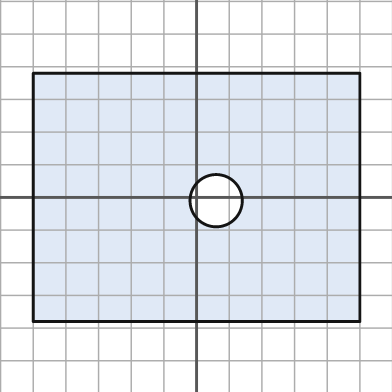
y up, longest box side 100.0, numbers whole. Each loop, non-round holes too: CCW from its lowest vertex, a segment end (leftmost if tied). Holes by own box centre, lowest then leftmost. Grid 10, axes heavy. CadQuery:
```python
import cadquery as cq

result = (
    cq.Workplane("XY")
    .moveTo(-50.0, -38.0)
    .lineTo(50.0, -38.0)
    .lineTo(50.0, 38.0)
    .lineTo(-50.0, 38.0)
    .close()
    .moveTo(6.0, -1.0)
    .circle(8.0)
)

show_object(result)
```